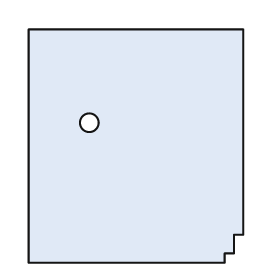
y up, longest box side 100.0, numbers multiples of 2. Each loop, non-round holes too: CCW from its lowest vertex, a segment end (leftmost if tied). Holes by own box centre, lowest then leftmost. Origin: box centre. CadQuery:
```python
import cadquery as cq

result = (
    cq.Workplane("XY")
    .moveTo(-46.0, -50.0)
    .lineTo(38.0, -50.0)
    .lineTo(38.0, -46.0)
    .lineTo(42.0, -46.0)
    .lineTo(42.0, -38.0)
    .lineTo(46.0, -38.0)
    .lineTo(46.0, 50.0)
    .lineTo(-46.0, 50.0)
    .close()
    .moveTo(-20.0, 10.0)
    .circle(4.0)
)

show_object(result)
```